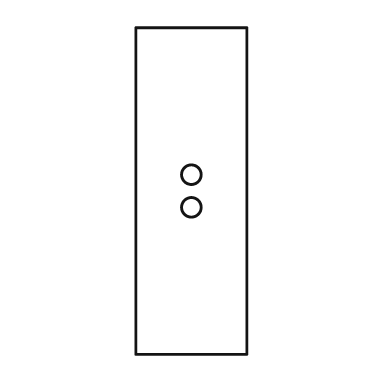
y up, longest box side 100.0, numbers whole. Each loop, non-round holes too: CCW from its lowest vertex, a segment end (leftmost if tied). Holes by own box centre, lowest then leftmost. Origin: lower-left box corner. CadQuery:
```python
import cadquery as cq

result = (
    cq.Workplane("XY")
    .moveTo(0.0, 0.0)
    .lineTo(34.0, 0.0)
    .lineTo(34.0, 100.0)
    .lineTo(0.0, 100.0)
    .close()
    .moveTo(17.0, 45.0)
    .circle(3.0)
    .moveTo(17.0, 55.0)
    .circle(3.0)
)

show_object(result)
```